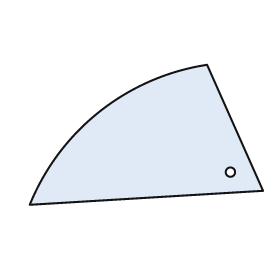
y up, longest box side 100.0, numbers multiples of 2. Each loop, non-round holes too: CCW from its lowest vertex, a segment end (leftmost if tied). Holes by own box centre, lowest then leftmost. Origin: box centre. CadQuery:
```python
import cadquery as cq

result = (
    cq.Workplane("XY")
    .moveTo(-50.0, -30.0)
    .lineTo(50.0, -24.0)
    .lineTo(26.0, 30.0)
    .threePointArc((-20.0, 10.0), (-50.0, -30.0))
    .close()
    .moveTo(36.0, -16.0)
    .circle(2.0)
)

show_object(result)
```